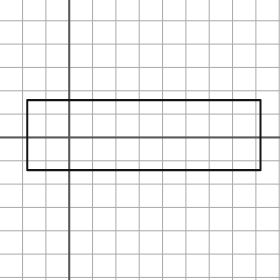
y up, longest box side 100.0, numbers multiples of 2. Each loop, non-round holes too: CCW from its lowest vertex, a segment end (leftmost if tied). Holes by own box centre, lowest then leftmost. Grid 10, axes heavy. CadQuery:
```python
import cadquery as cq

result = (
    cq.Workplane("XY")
    .moveTo(-18.0, -14.0)
    .lineTo(82.0, -14.0)
    .lineTo(82.0, 16.0)
    .lineTo(-18.0, 16.0)
    .close()
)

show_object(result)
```